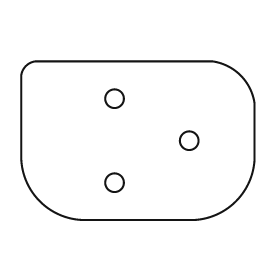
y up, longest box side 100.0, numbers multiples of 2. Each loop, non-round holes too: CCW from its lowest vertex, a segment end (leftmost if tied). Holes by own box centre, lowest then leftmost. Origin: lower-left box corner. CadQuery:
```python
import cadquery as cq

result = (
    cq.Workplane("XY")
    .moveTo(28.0, 0.0)
    .lineTo(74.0, 0.0)
    .threePointArc((92.0, 8.0), (100.0, 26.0))
    .lineTo(100.0, 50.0)
    .threePointArc((94.0, 62.0), (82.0, 68.0))
    .lineTo(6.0, 68.0)
    .threePointArc((2.0, 66.0), (0.0, 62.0))
    .lineTo(0.0, 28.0)
    .threePointArc((8.0, 8.0), (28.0, 0.0))
    .close()
    .moveTo(40.0, 16.0)
    .circle(4.0)
    .moveTo(72.0, 34.0)
    .circle(4.0)
    .moveTo(40.0, 52.0)
    .circle(4.0)
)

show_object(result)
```